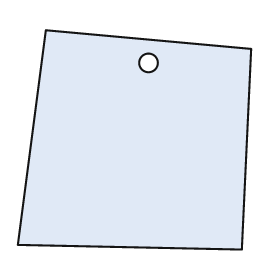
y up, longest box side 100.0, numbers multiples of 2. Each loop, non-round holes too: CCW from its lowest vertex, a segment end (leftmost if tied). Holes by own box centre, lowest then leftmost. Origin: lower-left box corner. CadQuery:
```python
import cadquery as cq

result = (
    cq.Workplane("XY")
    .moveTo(96.0, 0.0)
    .lineTo(100.0, 86.0)
    .lineTo(12.0, 94.0)
    .lineTo(0.0, 2.0)
    .close()
    .moveTo(56.0, 80.0)
    .circle(4.0)
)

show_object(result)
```